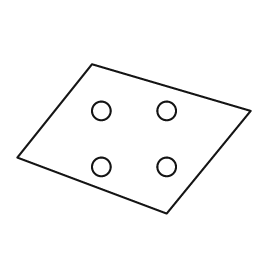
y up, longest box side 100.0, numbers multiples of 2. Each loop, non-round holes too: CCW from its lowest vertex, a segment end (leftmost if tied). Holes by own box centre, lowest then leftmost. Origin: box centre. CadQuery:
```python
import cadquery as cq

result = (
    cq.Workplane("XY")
    .moveTo(14.0, -32.0)
    .lineTo(50.0, 12.0)
    .lineTo(-18.0, 32.0)
    .lineTo(-50.0, -8.0)
    .close()
    .moveTo(-14.0, -12.0)
    .circle(4.0)
    .moveTo(14.0, -12.0)
    .circle(4.0)
    .moveTo(-14.0, 12.0)
    .circle(4.0)
    .moveTo(14.0, 12.0)
    .circle(4.0)
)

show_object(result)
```